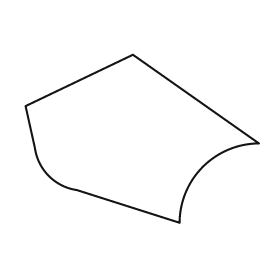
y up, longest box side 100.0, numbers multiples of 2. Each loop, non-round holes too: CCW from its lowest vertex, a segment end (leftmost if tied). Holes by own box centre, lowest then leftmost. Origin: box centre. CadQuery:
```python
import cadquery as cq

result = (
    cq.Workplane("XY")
    .moveTo(16.0, -36.0)
    .threePointArc((26.0, -12.0), (50.0, -2.0))
    .lineTo(-4.0, 36.0)
    .lineTo(-50.0, 14.0)
    .lineTo(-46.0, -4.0)
    .threePointArc((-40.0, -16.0), (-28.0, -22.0))
    .close()
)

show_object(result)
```